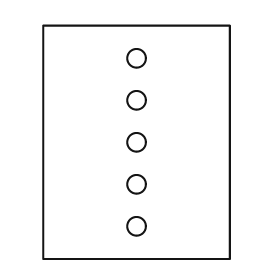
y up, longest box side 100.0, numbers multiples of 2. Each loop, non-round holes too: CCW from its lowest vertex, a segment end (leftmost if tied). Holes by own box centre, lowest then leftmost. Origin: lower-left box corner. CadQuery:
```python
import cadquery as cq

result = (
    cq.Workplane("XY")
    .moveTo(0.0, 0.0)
    .lineTo(80.0, 0.0)
    .lineTo(80.0, 100.0)
    .lineTo(0.0, 100.0)
    .close()
    .moveTo(40.0, 14.0)
    .circle(4.0)
    .moveTo(40.0, 32.0)
    .circle(4.0)
    .moveTo(40.0, 50.0)
    .circle(4.0)
    .moveTo(40.0, 68.0)
    .circle(4.0)
    .moveTo(40.0, 86.0)
    .circle(4.0)
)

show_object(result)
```